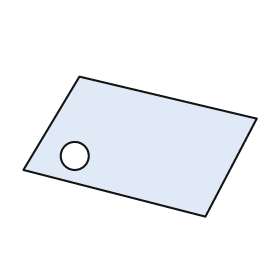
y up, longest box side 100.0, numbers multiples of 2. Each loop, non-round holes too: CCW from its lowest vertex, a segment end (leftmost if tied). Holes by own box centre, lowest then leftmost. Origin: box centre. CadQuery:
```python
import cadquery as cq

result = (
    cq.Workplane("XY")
    .moveTo(28.0, -30.0)
    .lineTo(50.0, 12.0)
    .lineTo(-26.0, 30.0)
    .lineTo(-50.0, -10.0)
    .close()
    .moveTo(-28.0, -4.0)
    .circle(6.0)
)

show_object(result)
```